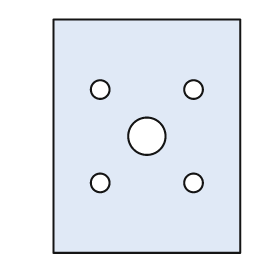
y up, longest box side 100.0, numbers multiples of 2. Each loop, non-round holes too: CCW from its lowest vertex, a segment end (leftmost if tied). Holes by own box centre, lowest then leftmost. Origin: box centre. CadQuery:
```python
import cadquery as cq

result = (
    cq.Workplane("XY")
    .moveTo(-40.0, -50.0)
    .lineTo(40.0, -50.0)
    .lineTo(40.0, 50.0)
    .lineTo(-40.0, 50.0)
    .close()
    .moveTo(-20.0, -20.0)
    .circle(4.0)
    .moveTo(20.0, -20.0)
    .circle(4.0)
    .moveTo(0.0, 0.0)
    .circle(8.0)
    .moveTo(-20.0, 20.0)
    .circle(4.0)
    .moveTo(20.0, 20.0)
    .circle(4.0)
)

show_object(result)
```